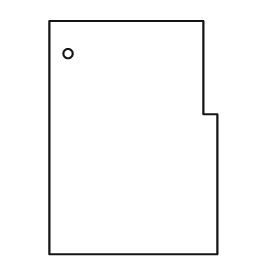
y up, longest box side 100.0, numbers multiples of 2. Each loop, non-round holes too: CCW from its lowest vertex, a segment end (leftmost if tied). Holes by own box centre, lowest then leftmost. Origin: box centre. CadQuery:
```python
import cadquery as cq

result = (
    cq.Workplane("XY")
    .moveTo(-36.0, -50.0)
    .lineTo(36.0, -50.0)
    .lineTo(36.0, 10.0)
    .lineTo(30.0, 10.0)
    .lineTo(30.0, 50.0)
    .lineTo(-36.0, 50.0)
    .close()
    .moveTo(-28.0, 36.0)
    .circle(2.0)
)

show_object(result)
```